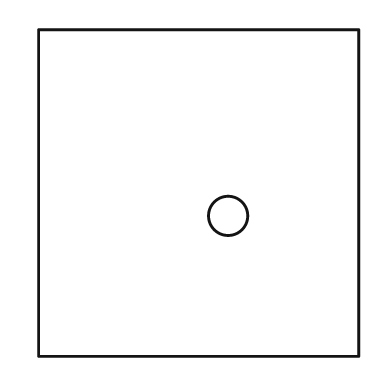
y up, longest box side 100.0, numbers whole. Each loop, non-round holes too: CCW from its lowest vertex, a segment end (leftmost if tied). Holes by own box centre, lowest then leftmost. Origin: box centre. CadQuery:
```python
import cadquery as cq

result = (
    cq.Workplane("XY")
    .moveTo(-49.0, -50.0)
    .lineTo(49.0, -50.0)
    .lineTo(49.0, 50.0)
    .lineTo(-49.0, 50.0)
    .close()
    .moveTo(9.0, -7.0)
    .circle(6.0)
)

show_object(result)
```